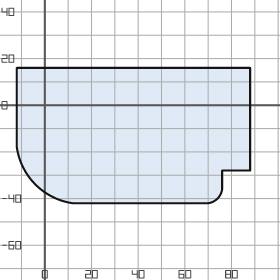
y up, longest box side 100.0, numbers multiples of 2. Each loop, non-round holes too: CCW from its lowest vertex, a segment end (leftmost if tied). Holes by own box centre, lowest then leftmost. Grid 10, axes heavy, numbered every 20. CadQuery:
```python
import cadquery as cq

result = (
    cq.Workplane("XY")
    .moveTo(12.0, -42.0)
    .lineTo(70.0, -42.0)
    .threePointArc((74.0, -40.0), (76.0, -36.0))
    .lineTo(76.0, -28.0)
    .lineTo(88.0, -28.0)
    .lineTo(88.0, 16.0)
    .lineTo(-12.0, 16.0)
    .lineTo(-12.0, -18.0)
    .threePointArc((-4.0, -34.0), (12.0, -42.0))
    .close()
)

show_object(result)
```